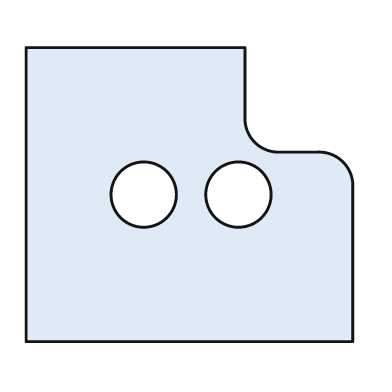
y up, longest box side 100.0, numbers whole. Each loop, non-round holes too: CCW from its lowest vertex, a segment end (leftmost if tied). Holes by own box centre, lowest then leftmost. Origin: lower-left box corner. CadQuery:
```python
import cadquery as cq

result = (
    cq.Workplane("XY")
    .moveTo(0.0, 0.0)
    .lineTo(100.0, 0.0)
    .lineTo(100.0, 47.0)
    .threePointArc((97.0, 55.0), (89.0, 58.0))
    .lineTo(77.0, 58.0)
    .threePointArc((70.0, 61.0), (67.0, 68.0))
    .lineTo(67.0, 90.0)
    .lineTo(0.0, 90.0)
    .close()
    .moveTo(36.0, 45.0)
    .circle(10.0)
    .moveTo(65.0, 45.0)
    .circle(10.0)
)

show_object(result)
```